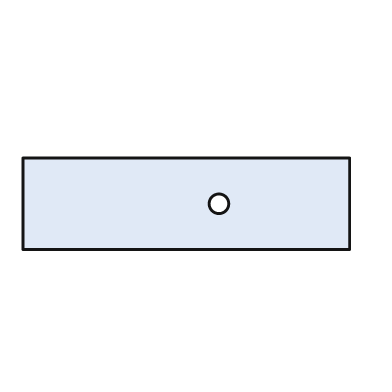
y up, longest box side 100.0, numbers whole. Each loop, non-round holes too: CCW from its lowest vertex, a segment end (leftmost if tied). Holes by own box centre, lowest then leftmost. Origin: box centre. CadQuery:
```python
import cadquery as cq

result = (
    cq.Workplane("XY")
    .moveTo(-50.0, -14.0)
    .lineTo(50.0, -14.0)
    .lineTo(50.0, 14.0)
    .lineTo(-50.0, 14.0)
    .close()
    .moveTo(10.0, 0.0)
    .circle(3.0)
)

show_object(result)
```